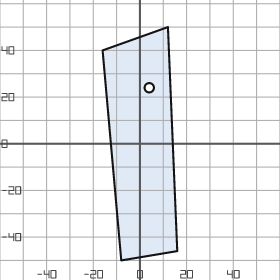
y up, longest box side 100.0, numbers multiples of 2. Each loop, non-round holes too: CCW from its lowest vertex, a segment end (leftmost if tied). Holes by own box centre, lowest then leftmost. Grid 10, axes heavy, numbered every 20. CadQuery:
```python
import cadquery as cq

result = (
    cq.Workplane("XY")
    .moveTo(-8.0, -50.0)
    .lineTo(16.0, -46.0)
    .lineTo(12.0, 50.0)
    .lineTo(-16.0, 40.0)
    .close()
    .moveTo(4.0, 24.0)
    .circle(2.0)
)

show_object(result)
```